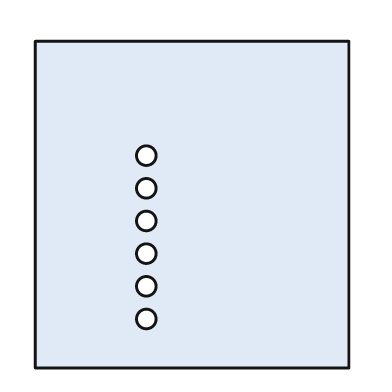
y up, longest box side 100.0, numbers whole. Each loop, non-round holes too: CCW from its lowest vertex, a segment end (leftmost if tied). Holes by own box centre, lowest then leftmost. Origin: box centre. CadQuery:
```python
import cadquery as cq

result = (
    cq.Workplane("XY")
    .moveTo(-48.0, -50.0)
    .lineTo(48.0, -50.0)
    .lineTo(48.0, 50.0)
    .lineTo(-48.0, 50.0)
    .close()
    .moveTo(-14.0, -35.0)
    .circle(3.0)
    .moveTo(-14.0, -25.0)
    .circle(3.0)
    .moveTo(-14.0, -15.0)
    .circle(3.0)
    .moveTo(-14.0, -5.0)
    .circle(3.0)
    .moveTo(-14.0, 5.0)
    .circle(3.0)
    .moveTo(-14.0, 15.0)
    .circle(3.0)
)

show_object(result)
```